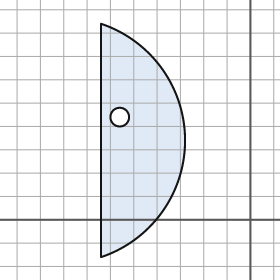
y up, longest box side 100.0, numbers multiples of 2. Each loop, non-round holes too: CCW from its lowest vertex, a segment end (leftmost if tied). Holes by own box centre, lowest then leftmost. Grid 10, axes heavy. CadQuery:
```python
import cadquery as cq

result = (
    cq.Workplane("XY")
    .moveTo(-64.0, -16.0)
    .threePointArc((-28.0, 34.0), (-64.0, 84.0))
    .close()
    .moveTo(-56.0, 44.0)
    .circle(4.0)
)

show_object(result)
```